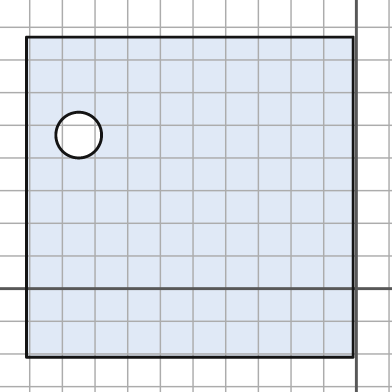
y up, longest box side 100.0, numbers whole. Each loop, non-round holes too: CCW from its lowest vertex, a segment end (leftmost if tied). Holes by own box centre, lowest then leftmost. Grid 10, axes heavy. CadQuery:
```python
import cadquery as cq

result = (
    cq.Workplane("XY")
    .moveTo(-101.0, -21.0)
    .lineTo(-1.0, -21.0)
    .lineTo(-1.0, 77.0)
    .lineTo(-101.0, 77.0)
    .close()
    .moveTo(-85.0, 47.0)
    .circle(7.0)
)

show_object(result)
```